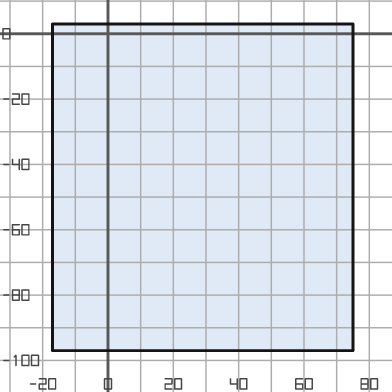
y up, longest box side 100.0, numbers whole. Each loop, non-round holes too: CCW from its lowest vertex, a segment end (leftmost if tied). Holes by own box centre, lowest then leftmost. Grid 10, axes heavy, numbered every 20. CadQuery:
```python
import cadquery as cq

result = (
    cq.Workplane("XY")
    .moveTo(-17.0, -97.0)
    .lineTo(75.0, -97.0)
    .lineTo(75.0, 3.0)
    .lineTo(-17.0, 3.0)
    .close()
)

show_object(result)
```